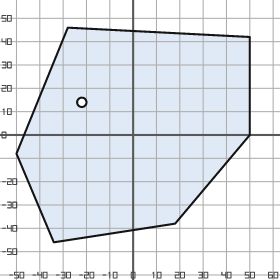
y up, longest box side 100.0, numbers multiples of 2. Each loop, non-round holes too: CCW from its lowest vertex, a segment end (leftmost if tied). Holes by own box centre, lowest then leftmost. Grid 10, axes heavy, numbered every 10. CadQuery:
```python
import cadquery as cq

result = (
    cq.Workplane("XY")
    .moveTo(-34.0, -46.0)
    .lineTo(18.0, -38.0)
    .lineTo(50.0, 0.0)
    .lineTo(50.0, 42.0)
    .lineTo(-28.0, 46.0)
    .lineTo(-50.0, -8.0)
    .close()
    .moveTo(-22.0, 14.0)
    .circle(2.0)
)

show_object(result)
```